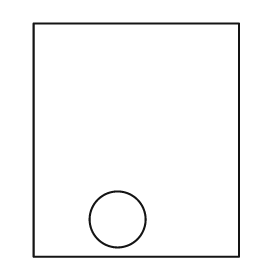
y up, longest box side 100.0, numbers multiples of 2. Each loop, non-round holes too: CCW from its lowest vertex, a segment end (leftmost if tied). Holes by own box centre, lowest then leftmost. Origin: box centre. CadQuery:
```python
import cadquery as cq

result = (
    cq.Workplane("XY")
    .moveTo(-44.0, -50.0)
    .lineTo(44.0, -50.0)
    .lineTo(44.0, 50.0)
    .lineTo(-44.0, 50.0)
    .close()
    .moveTo(-8.0, -34.0)
    .circle(12.0)
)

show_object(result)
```